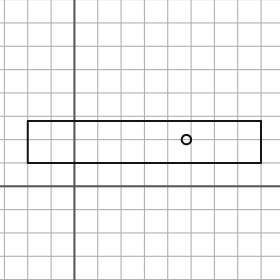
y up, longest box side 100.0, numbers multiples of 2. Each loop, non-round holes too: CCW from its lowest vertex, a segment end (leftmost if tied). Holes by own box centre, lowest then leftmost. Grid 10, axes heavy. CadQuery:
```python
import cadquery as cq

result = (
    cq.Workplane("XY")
    .moveTo(-20.0, 10.0)
    .lineTo(80.0, 10.0)
    .lineTo(80.0, 28.0)
    .lineTo(-20.0, 28.0)
    .close()
    .moveTo(48.0, 20.0)
    .circle(2.0)
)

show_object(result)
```